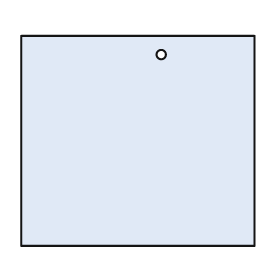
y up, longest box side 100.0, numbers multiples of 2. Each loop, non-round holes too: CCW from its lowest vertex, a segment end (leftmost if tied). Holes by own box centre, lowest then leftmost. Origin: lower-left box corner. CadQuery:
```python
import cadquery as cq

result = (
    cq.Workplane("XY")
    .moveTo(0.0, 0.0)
    .lineTo(100.0, 0.0)
    .lineTo(100.0, 90.0)
    .lineTo(0.0, 90.0)
    .close()
    .moveTo(60.0, 82.0)
    .circle(2.0)
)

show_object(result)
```